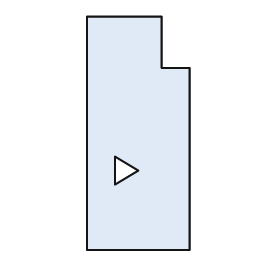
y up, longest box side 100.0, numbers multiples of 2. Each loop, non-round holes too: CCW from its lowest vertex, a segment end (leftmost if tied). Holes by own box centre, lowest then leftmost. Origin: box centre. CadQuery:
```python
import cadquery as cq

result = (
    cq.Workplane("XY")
    .moveTo(-22.0, -50.0)
    .lineTo(22.0, -50.0)
    .lineTo(22.0, 28.0)
    .lineTo(10.0, 28.0)
    .lineTo(10.0, 50.0)
    .lineTo(-22.0, 50.0)
    .close()
    .moveTo(-10.0, -22.0)
    .lineTo(0.0, -16.0)
    .lineTo(-10.0, -10.0)
    .close()
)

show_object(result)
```